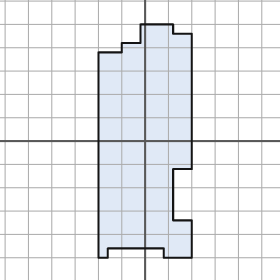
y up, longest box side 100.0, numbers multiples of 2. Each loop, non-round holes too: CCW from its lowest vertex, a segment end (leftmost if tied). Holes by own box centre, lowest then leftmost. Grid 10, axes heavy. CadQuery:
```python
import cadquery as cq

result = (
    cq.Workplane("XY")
    .moveTo(-20.0, -50.0)
    .lineTo(-16.0, -50.0)
    .lineTo(-16.0, -46.0)
    .lineTo(8.0, -46.0)
    .lineTo(8.0, -50.0)
    .lineTo(20.0, -50.0)
    .lineTo(20.0, -34.0)
    .lineTo(12.0, -34.0)
    .lineTo(12.0, -12.0)
    .lineTo(20.0, -12.0)
    .lineTo(20.0, 46.0)
    .lineTo(12.0, 46.0)
    .lineTo(12.0, 50.0)
    .lineTo(-2.0, 50.0)
    .lineTo(-2.0, 42.0)
    .lineTo(-10.0, 42.0)
    .lineTo(-10.0, 38.0)
    .lineTo(-20.0, 38.0)
    .close()
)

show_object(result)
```